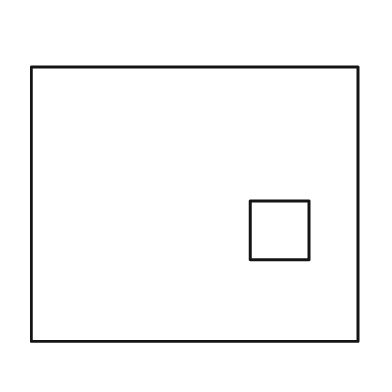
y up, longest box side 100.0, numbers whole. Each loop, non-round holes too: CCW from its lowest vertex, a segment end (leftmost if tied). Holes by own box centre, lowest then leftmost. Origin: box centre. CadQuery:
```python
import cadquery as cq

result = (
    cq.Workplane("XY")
    .moveTo(-50.0, -42.0)
    .lineTo(50.0, -42.0)
    .lineTo(50.0, 42.0)
    .lineTo(-50.0, 42.0)
    .close()
    .moveTo(17.0, -17.0)
    .lineTo(35.0, -17.0)
    .lineTo(35.0, 1.0)
    .lineTo(17.0, 1.0)
    .close()
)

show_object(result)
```